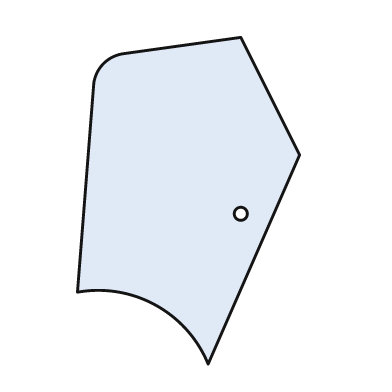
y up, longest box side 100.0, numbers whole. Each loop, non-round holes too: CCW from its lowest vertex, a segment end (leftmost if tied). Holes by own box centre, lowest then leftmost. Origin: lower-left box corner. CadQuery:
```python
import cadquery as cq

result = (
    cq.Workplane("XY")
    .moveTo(40.0, 0.0)
    .lineTo(68.0, 64.0)
    .lineTo(50.0, 100.0)
    .lineTo(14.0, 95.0)
    .threePointArc((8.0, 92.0), (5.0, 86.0))
    .lineTo(0.0, 22.0)
    .threePointArc((24.0, 18.0), (40.0, 0.0))
    .close()
    .moveTo(50.0, 46.0)
    .circle(2.0)
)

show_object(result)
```